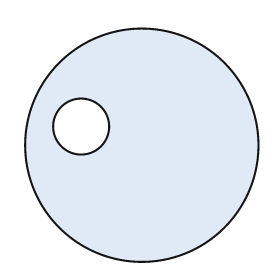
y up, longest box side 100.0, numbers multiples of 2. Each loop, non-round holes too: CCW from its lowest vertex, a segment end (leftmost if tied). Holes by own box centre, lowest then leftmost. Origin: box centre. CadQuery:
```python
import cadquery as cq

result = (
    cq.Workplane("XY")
    .moveTo(0.0, 0.0)
    .circle(50.0)
    .moveTo(-26.0, 8.0)
    .circle(12.0)
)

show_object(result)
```